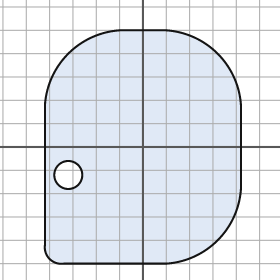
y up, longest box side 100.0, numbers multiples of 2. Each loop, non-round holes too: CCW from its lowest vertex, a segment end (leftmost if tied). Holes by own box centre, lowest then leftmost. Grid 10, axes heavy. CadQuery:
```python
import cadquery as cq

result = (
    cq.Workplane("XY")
    .moveTo(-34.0, -50.0)
    .lineTo(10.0, -50.0)
    .threePointArc((32.0, -40.0), (42.0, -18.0))
    .lineTo(42.0, 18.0)
    .threePointArc((32.0, 40.0), (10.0, 50.0))
    .lineTo(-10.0, 50.0)
    .threePointArc((-32.0, 40.0), (-42.0, 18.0))
    .lineTo(-42.0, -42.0)
    .threePointArc((-40.0, -48.0), (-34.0, -50.0))
    .close()
    .moveTo(-32.0, -12.0)
    .circle(6.0)
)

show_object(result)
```